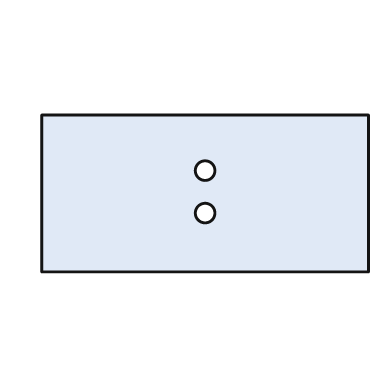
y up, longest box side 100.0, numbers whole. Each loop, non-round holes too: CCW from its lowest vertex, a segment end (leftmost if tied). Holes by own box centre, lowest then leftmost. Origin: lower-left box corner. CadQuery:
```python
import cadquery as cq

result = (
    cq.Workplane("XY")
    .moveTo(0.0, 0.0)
    .lineTo(100.0, 0.0)
    .lineTo(100.0, 48.0)
    .lineTo(0.0, 48.0)
    .close()
    .moveTo(50.0, 18.0)
    .circle(3.0)
    .moveTo(50.0, 31.0)
    .circle(3.0)
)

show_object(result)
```